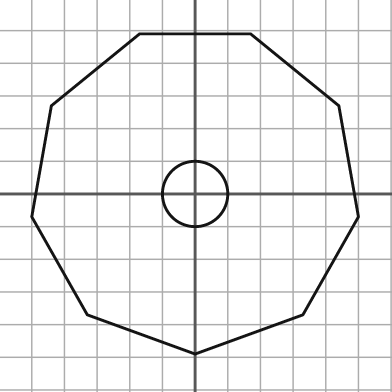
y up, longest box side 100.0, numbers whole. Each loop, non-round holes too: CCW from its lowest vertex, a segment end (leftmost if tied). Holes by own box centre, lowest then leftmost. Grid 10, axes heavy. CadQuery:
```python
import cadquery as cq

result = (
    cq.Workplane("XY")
    .moveTo(0.0, -49.0)
    .lineTo(33.0, -37.0)
    .lineTo(50.0, -7.0)
    .lineTo(44.0, 27.0)
    .lineTo(17.0, 49.0)
    .lineTo(-17.0, 49.0)
    .lineTo(-44.0, 27.0)
    .lineTo(-50.0, -7.0)
    .lineTo(-33.0, -37.0)
    .close()
    .moveTo(0.0, 0.0)
    .circle(10.0)
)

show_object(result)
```